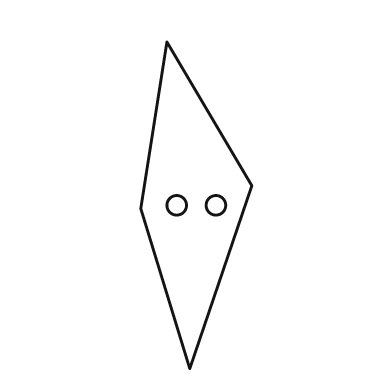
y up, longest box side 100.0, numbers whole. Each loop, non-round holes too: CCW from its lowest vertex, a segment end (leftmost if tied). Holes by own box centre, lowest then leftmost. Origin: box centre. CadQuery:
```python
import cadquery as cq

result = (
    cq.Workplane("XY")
    .moveTo(-2.0, -50.0)
    .lineTo(17.0, 6.0)
    .lineTo(-9.0, 50.0)
    .lineTo(-17.0, -1.0)
    .close()
    .moveTo(-6.0, 0.0)
    .circle(3.0)
    .moveTo(6.0, 0.0)
    .circle(3.0)
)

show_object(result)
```